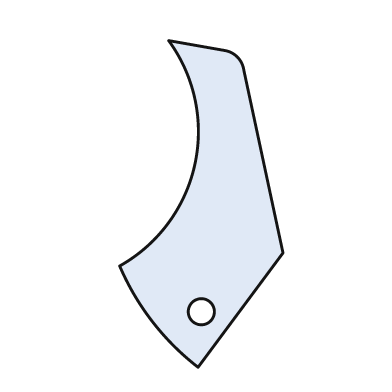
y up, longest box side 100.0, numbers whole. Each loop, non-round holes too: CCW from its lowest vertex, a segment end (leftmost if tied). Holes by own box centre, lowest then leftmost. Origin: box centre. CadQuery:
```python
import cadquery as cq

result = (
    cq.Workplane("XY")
    .moveTo(-1.0, -50.0)
    .lineTo(25.0, -15.0)
    .lineTo(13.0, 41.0)
    .threePointArc((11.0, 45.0), (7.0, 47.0))
    .lineTo(-10.0, 50.0)
    .threePointArc((-2.0, 12.0), (-25.0, -19.0))
    .threePointArc((-15.0, -36.0), (-1.0, -50.0))
    .close()
    .moveTo(0.0, -33.0)
    .circle(4.0)
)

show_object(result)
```